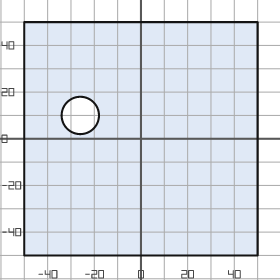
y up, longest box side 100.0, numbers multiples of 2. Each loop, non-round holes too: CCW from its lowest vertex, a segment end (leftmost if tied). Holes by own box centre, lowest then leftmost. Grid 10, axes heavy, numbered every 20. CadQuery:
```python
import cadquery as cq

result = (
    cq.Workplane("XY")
    .moveTo(-50.0, -50.0)
    .lineTo(50.0, -50.0)
    .lineTo(50.0, 50.0)
    .lineTo(-50.0, 50.0)
    .close()
    .moveTo(-26.0, 10.0)
    .circle(8.0)
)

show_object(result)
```